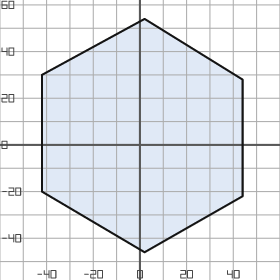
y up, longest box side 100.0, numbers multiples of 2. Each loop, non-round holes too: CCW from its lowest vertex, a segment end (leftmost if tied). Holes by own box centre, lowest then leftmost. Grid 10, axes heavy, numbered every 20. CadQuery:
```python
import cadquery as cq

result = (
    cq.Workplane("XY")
    .moveTo(2.0, -46.0)
    .lineTo(44.0, -22.0)
    .lineTo(44.0, 28.0)
    .lineTo(2.0, 54.0)
    .lineTo(-42.0, 30.0)
    .lineTo(-42.0, -20.0)
    .close()
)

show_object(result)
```